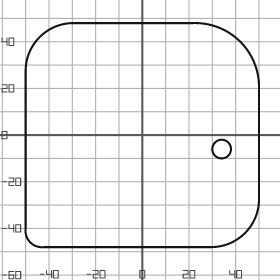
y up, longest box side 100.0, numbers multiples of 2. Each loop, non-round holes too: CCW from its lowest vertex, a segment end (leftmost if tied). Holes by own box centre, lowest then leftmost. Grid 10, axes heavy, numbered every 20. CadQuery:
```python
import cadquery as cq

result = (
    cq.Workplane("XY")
    .moveTo(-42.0, -48.0)
    .lineTo(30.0, -48.0)
    .threePointArc((44.0, -42.0), (50.0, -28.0))
    .lineTo(50.0, 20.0)
    .threePointArc((42.0, 40.0), (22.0, 48.0))
    .lineTo(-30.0, 48.0)
    .threePointArc((-44.0, 42.0), (-50.0, 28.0))
    .lineTo(-50.0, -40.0)
    .threePointArc((-48.0, -46.0), (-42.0, -48.0))
    .close()
    .moveTo(34.0, -6.0)
    .circle(4.0)
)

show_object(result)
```